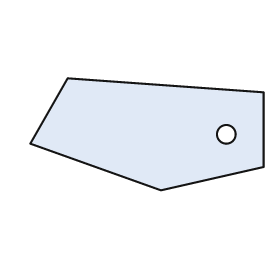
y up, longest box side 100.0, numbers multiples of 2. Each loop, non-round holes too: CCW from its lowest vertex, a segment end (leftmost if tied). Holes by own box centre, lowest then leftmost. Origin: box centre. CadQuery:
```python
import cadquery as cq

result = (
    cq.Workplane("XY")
    .moveTo(6.0, -24.0)
    .lineTo(50.0, -14.0)
    .lineTo(50.0, 18.0)
    .lineTo(-34.0, 24.0)
    .lineTo(-50.0, -4.0)
    .close()
    .moveTo(34.0, 0.0)
    .circle(4.0)
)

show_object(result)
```